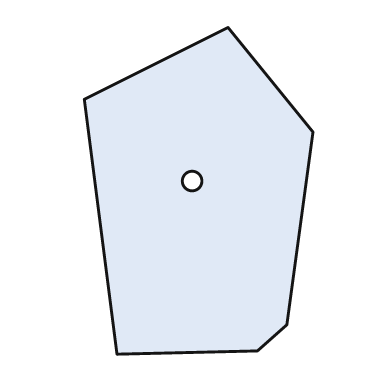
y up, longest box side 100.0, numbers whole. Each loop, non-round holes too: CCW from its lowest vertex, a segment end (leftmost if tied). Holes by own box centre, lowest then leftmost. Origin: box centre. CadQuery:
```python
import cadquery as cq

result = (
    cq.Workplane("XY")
    .moveTo(-25.0, -50.0)
    .lineTo(18.0, -49.0)
    .lineTo(27.0, -41.0)
    .lineTo(35.0, 18.0)
    .lineTo(9.0, 50.0)
    .lineTo(-35.0, 28.0)
    .close()
    .moveTo(-2.0, 3.0)
    .circle(3.0)
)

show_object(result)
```